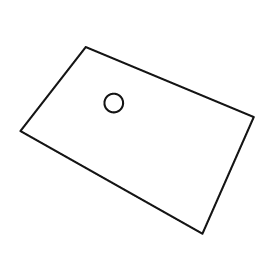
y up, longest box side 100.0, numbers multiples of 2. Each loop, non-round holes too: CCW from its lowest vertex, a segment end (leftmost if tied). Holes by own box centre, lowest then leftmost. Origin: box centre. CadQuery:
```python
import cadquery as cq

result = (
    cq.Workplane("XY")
    .moveTo(28.0, -40.0)
    .lineTo(50.0, 10.0)
    .lineTo(-22.0, 40.0)
    .lineTo(-50.0, 4.0)
    .close()
    .moveTo(-10.0, 16.0)
    .circle(4.0)
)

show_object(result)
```